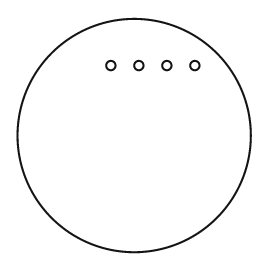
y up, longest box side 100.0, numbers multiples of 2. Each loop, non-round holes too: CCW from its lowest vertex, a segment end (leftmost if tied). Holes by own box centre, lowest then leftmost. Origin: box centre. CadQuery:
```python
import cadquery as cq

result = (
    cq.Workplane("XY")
    .moveTo(0.0, 0.0)
    .circle(50.0)
    .moveTo(-10.0, 30.0)
    .circle(2.0)
    .moveTo(2.0, 30.0)
    .circle(2.0)
    .moveTo(14.0, 30.0)
    .circle(2.0)
    .moveTo(26.0, 30.0)
    .circle(2.0)
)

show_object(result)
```